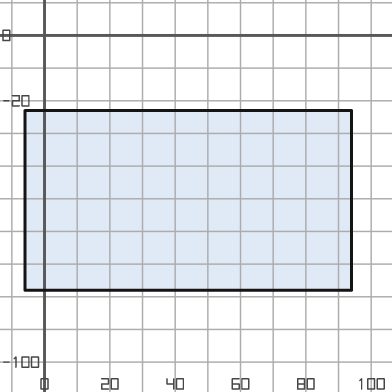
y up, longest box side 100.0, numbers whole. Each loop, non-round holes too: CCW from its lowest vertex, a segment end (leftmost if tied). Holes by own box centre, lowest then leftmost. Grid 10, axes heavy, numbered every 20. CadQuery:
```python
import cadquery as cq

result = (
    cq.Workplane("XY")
    .moveTo(-6.0, -78.0)
    .lineTo(94.0, -78.0)
    .lineTo(94.0, -23.0)
    .lineTo(-6.0, -23.0)
    .close()
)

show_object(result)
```